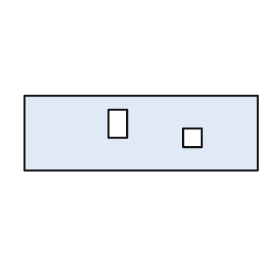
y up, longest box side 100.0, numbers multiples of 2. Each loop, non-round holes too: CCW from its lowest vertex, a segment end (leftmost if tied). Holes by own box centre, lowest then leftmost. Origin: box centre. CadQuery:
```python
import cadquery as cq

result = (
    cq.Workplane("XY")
    .moveTo(-50.0, -16.0)
    .lineTo(50.0, -16.0)
    .lineTo(50.0, 16.0)
    .lineTo(-50.0, 16.0)
    .close()
    .moveTo(18.0, -6.0)
    .lineTo(26.0, -6.0)
    .lineTo(26.0, 2.0)
    .lineTo(18.0, 2.0)
    .close()
    .moveTo(-14.0, -2.0)
    .lineTo(-6.0, -2.0)
    .lineTo(-6.0, 10.0)
    .lineTo(-14.0, 10.0)
    .close()
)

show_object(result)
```